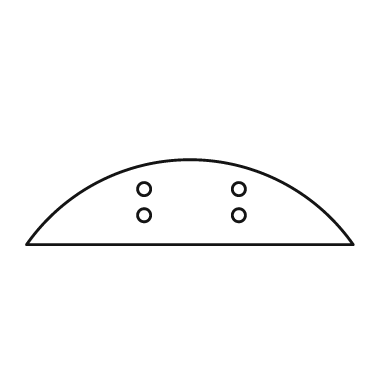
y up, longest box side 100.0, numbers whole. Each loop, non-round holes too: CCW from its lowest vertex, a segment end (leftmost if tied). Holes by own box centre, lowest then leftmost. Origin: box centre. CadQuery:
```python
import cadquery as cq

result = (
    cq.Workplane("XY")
    .moveTo(-50.0, -13.0)
    .lineTo(50.0, -13.0)
    .threePointArc((0.0, 13.0), (-50.0, -13.0))
    .close()
    .moveTo(-14.0, -4.0)
    .circle(2.0)
    .moveTo(15.0, -4.0)
    .circle(2.0)
    .moveTo(-14.0, 4.0)
    .circle(2.0)
    .moveTo(15.0, 4.0)
    .circle(2.0)
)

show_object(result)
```